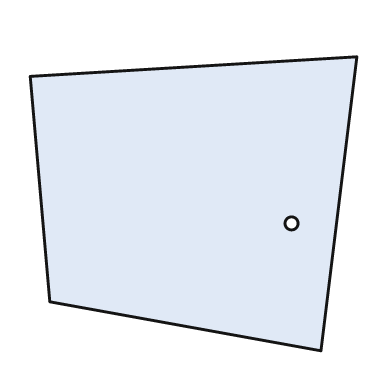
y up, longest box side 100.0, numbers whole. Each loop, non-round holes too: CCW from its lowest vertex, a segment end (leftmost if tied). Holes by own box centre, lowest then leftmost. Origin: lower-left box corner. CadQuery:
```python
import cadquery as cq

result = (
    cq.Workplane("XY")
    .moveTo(89.0, 0.0)
    .lineTo(100.0, 90.0)
    .lineTo(0.0, 84.0)
    .lineTo(6.0, 15.0)
    .close()
    .moveTo(80.0, 39.0)
    .circle(2.0)
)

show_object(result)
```